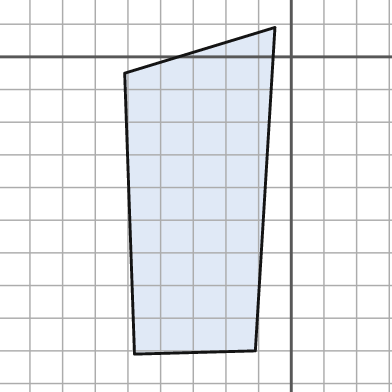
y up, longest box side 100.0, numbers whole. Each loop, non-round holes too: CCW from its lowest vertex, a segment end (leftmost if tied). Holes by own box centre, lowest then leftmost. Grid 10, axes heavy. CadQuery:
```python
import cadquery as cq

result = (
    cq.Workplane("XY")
    .moveTo(-48.0, -91.0)
    .lineTo(-11.0, -90.0)
    .lineTo(-5.0, 9.0)
    .lineTo(-51.0, -5.0)
    .close()
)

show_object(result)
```